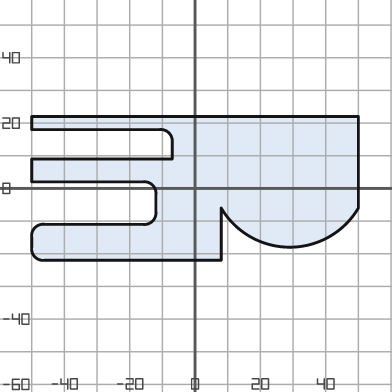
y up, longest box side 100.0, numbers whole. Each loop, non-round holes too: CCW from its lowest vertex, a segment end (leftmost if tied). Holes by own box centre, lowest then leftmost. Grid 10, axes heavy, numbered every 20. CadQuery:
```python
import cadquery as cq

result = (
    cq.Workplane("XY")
    .moveTo(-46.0, -22.0)
    .lineTo(8.0, -22.0)
    .lineTo(8.0, -6.0)
    .threePointArc((29.0, -18.0), (50.0, -6.0))
    .lineTo(50.0, 22.0)
    .lineTo(-50.0, 22.0)
    .lineTo(-50.0, 18.0)
    .lineTo(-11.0, 18.0)
    .threePointArc((-8.0, 17.0), (-7.0, 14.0))
    .lineTo(-7.0, 9.0)
    .lineTo(-50.0, 9.0)
    .lineTo(-50.0, 2.0)
    .lineTo(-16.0, 2.0)
    .threePointArc((-13.0, 1.0), (-12.0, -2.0))
    .lineTo(-12.0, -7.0)
    .threePointArc((-13.0, -10.0), (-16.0, -11.0))
    .lineTo(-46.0, -11.0)
    .threePointArc((-49.0, -12.0), (-50.0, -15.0))
    .lineTo(-50.0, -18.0)
    .threePointArc((-49.0, -21.0), (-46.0, -22.0))
    .close()
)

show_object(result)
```